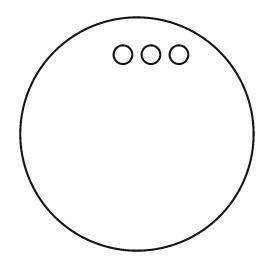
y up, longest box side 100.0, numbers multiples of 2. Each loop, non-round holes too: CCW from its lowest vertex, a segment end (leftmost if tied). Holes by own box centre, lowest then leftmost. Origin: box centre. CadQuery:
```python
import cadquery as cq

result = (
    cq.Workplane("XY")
    .moveTo(0.0, 0.0)
    .circle(50.0)
    .moveTo(-6.0, 34.0)
    .circle(4.0)
    .moveTo(6.0, 34.0)
    .circle(4.0)
    .moveTo(18.0, 34.0)
    .circle(4.0)
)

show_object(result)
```